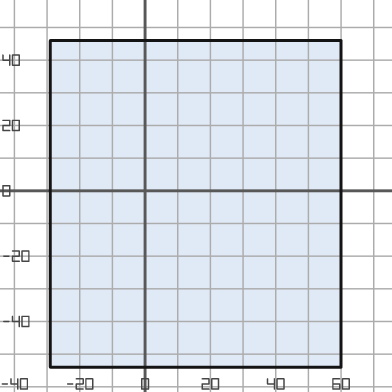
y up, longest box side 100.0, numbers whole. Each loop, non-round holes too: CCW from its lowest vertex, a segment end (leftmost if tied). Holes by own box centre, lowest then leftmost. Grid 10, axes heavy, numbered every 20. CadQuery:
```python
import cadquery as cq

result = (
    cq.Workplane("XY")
    .moveTo(-29.0, -54.0)
    .lineTo(60.0, -54.0)
    .lineTo(60.0, 46.0)
    .lineTo(-29.0, 46.0)
    .close()
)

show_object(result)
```